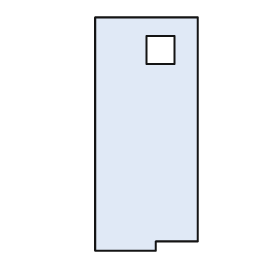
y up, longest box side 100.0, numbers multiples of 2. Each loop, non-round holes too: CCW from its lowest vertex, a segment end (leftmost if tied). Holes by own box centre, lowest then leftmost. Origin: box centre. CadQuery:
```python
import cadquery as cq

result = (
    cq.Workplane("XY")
    .moveTo(-22.0, -50.0)
    .lineTo(4.0, -50.0)
    .lineTo(4.0, -46.0)
    .lineTo(22.0, -46.0)
    .lineTo(22.0, 50.0)
    .lineTo(-22.0, 50.0)
    .close()
    .moveTo(0.0, 30.0)
    .lineTo(12.0, 30.0)
    .lineTo(12.0, 42.0)
    .lineTo(0.0, 42.0)
    .close()
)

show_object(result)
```